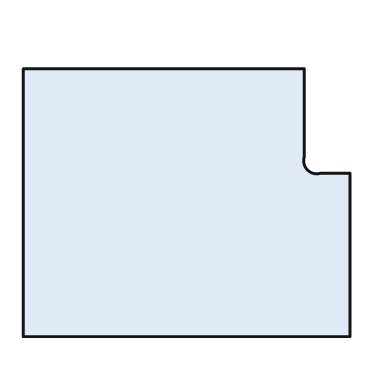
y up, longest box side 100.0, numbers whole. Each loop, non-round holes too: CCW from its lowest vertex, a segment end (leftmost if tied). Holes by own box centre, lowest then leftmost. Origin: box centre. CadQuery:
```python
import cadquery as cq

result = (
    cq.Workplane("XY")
    .moveTo(-50.0, -41.0)
    .lineTo(50.0, -41.0)
    .lineTo(50.0, 9.0)
    .lineTo(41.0, 9.0)
    .threePointArc((37.0, 10.0), (36.0, 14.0))
    .lineTo(36.0, 41.0)
    .lineTo(-50.0, 41.0)
    .close()
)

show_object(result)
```